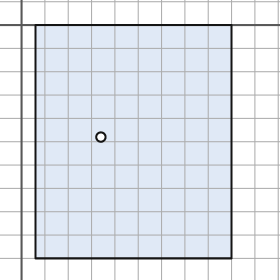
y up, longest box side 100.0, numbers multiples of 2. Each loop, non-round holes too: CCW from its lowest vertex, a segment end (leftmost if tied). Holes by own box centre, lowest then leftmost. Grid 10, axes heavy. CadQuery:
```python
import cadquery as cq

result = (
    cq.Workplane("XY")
    .moveTo(6.0, -100.0)
    .lineTo(90.0, -100.0)
    .lineTo(90.0, 0.0)
    .lineTo(6.0, 0.0)
    .close()
    .moveTo(34.0, -48.0)
    .circle(2.0)
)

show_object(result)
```